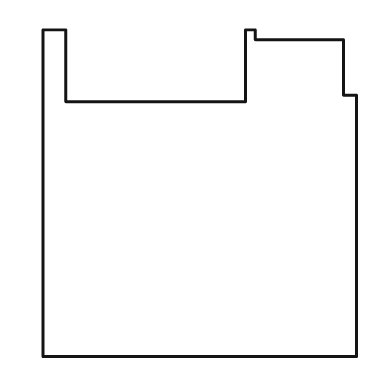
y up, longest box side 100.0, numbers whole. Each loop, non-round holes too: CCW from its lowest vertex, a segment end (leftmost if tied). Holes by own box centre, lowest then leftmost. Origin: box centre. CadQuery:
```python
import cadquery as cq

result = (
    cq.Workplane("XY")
    .moveTo(-48.0, -50.0)
    .lineTo(48.0, -50.0)
    .lineTo(48.0, 30.0)
    .lineTo(44.0, 30.0)
    .lineTo(44.0, 47.0)
    .lineTo(17.0, 47.0)
    .lineTo(17.0, 50.0)
    .lineTo(14.0, 50.0)
    .lineTo(14.0, 28.0)
    .lineTo(-41.0, 28.0)
    .lineTo(-41.0, 50.0)
    .lineTo(-48.0, 50.0)
    .close()
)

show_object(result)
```